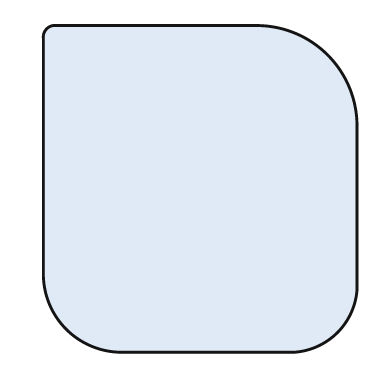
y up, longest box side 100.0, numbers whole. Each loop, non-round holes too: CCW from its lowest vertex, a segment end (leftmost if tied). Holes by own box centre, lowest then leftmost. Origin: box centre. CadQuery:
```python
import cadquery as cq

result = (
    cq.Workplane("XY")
    .moveTo(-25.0, -50.0)
    .lineTo(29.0, -50.0)
    .threePointArc((42.0, -44.0), (48.0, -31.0))
    .lineTo(48.0, 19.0)
    .threePointArc((39.0, 41.0), (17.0, 50.0))
    .lineTo(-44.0, 50.0)
    .threePointArc((-47.0, 49.0), (-48.0, 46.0))
    .lineTo(-48.0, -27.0)
    .threePointArc((-41.0, -43.0), (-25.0, -50.0))
    .close()
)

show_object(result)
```